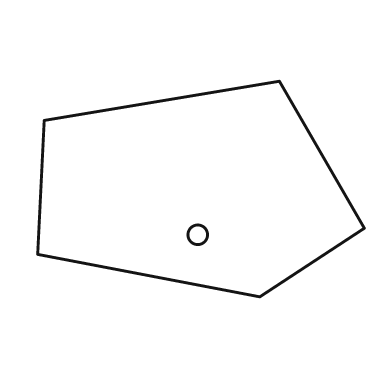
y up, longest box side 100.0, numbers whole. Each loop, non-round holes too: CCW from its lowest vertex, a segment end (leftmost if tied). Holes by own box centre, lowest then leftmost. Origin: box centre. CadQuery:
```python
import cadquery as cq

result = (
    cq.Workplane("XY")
    .moveTo(18.0, -33.0)
    .lineTo(50.0, -12.0)
    .lineTo(24.0, 33.0)
    .lineTo(-48.0, 21.0)
    .lineTo(-50.0, -20.0)
    .close()
    .moveTo(-1.0, -14.0)
    .circle(3.0)
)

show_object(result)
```